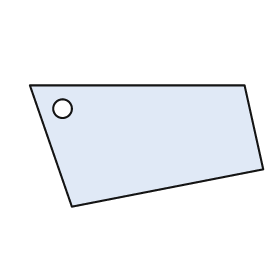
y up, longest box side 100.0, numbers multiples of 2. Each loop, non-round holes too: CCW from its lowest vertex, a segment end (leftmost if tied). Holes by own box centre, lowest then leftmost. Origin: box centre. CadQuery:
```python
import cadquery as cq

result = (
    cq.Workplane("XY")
    .moveTo(-32.0, -26.0)
    .lineTo(50.0, -10.0)
    .lineTo(42.0, 26.0)
    .lineTo(-50.0, 26.0)
    .close()
    .moveTo(-36.0, 16.0)
    .circle(4.0)
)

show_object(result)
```